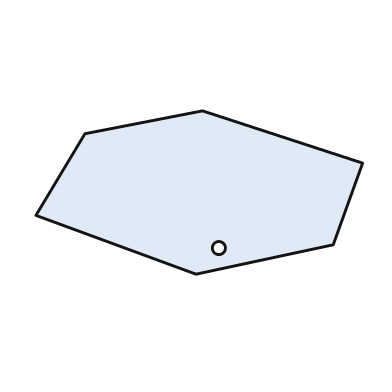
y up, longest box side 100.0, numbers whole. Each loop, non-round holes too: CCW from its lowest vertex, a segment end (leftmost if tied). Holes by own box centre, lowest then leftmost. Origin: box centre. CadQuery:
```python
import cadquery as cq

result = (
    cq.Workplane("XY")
    .moveTo(-1.0, -25.0)
    .lineTo(41.0, -16.0)
    .lineTo(50.0, 9.0)
    .lineTo(1.0, 25.0)
    .lineTo(-35.0, 18.0)
    .lineTo(-50.0, -7.0)
    .close()
    .moveTo(6.0, -17.0)
    .circle(2.0)
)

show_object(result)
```